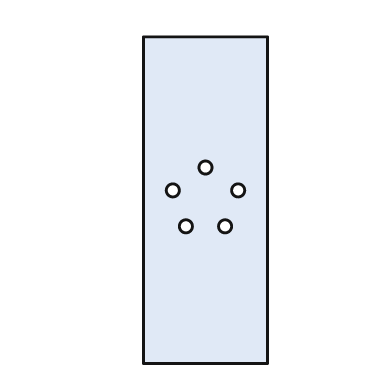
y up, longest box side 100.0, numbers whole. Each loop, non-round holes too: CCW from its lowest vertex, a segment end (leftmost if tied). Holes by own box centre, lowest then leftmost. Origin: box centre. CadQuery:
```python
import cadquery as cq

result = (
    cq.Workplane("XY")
    .moveTo(-19.0, -50.0)
    .lineTo(19.0, -50.0)
    .lineTo(19.0, 50.0)
    .lineTo(-19.0, 50.0)
    .close()
    .moveTo(-6.0, -8.0)
    .circle(2.0)
    .moveTo(6.0, -8.0)
    .circle(2.0)
    .moveTo(-10.0, 3.0)
    .circle(2.0)
    .moveTo(10.0, 3.0)
    .circle(2.0)
    .moveTo(0.0, 10.0)
    .circle(2.0)
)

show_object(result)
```